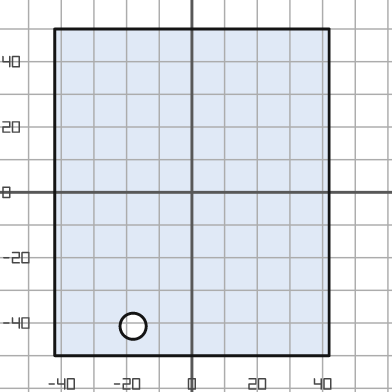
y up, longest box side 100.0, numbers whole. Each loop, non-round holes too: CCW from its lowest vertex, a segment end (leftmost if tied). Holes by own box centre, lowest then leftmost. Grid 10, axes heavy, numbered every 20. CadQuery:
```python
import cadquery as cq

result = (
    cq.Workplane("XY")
    .moveTo(-42.0, -50.0)
    .lineTo(42.0, -50.0)
    .lineTo(42.0, 50.0)
    .lineTo(-42.0, 50.0)
    .close()
    .moveTo(-18.0, -41.0)
    .circle(4.0)
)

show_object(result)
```